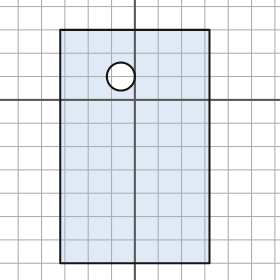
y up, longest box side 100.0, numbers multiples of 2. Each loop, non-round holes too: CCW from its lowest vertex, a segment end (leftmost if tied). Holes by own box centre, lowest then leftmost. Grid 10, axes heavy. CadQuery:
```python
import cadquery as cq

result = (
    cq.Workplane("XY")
    .moveTo(-32.0, -70.0)
    .lineTo(32.0, -70.0)
    .lineTo(32.0, 30.0)
    .lineTo(-32.0, 30.0)
    .close()
    .moveTo(-6.0, 10.0)
    .circle(6.0)
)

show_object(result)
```